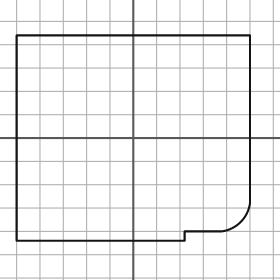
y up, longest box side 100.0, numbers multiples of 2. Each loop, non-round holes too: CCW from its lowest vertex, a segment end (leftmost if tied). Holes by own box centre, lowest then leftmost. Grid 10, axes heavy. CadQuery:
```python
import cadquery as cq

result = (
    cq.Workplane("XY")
    .moveTo(-50.0, -44.0)
    .lineTo(22.0, -44.0)
    .lineTo(22.0, -40.0)
    .lineTo(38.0, -40.0)
    .threePointArc((46.0, -36.0), (50.0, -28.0))
    .lineTo(50.0, 44.0)
    .lineTo(-50.0, 44.0)
    .close()
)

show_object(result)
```